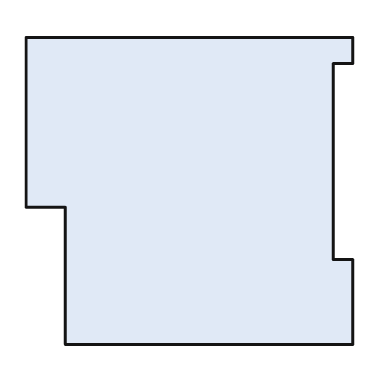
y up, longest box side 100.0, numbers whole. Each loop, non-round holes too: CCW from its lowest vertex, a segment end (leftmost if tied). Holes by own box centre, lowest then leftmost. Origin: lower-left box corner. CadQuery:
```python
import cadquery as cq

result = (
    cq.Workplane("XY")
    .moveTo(12.0, 0.0)
    .lineTo(100.0, 0.0)
    .lineTo(100.0, 26.0)
    .lineTo(94.0, 26.0)
    .lineTo(94.0, 86.0)
    .lineTo(100.0, 86.0)
    .lineTo(100.0, 94.0)
    .lineTo(0.0, 94.0)
    .lineTo(0.0, 42.0)
    .lineTo(12.0, 42.0)
    .close()
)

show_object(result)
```